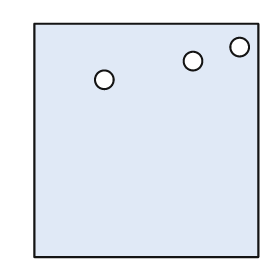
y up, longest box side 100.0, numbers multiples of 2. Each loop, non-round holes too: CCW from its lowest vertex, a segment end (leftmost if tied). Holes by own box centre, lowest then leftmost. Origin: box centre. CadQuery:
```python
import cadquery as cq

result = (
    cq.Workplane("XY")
    .moveTo(-48.0, -50.0)
    .lineTo(48.0, -50.0)
    .lineTo(48.0, 50.0)
    .lineTo(-48.0, 50.0)
    .close()
    .moveTo(-18.0, 26.0)
    .circle(4.0)
    .moveTo(20.0, 34.0)
    .circle(4.0)
    .moveTo(40.0, 40.0)
    .circle(4.0)
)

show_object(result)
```